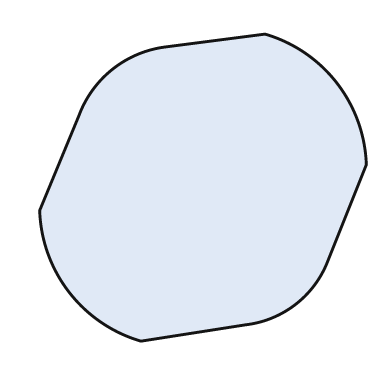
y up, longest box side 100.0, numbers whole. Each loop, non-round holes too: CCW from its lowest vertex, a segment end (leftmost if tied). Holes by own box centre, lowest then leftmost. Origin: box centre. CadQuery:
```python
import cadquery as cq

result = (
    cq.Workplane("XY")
    .moveTo(-19.0, -47.0)
    .lineTo(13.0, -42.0)
    .threePointArc((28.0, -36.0), (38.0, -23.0))
    .lineTo(50.0, 7.0)
    .threePointArc((41.0, 32.0), (19.0, 47.0))
    .lineTo(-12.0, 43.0)
    .threePointArc((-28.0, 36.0), (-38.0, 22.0))
    .lineTo(-50.0, -7.0)
    .threePointArc((-41.0, -32.0), (-19.0, -47.0))
    .close()
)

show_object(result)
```